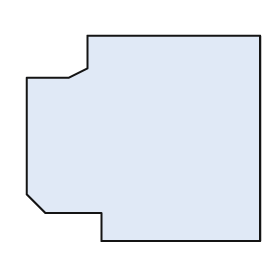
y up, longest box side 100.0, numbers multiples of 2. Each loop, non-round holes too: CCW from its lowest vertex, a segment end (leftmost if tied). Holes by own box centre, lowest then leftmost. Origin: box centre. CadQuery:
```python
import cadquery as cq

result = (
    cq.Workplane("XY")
    .moveTo(-18.0, -44.0)
    .lineTo(50.0, -44.0)
    .lineTo(50.0, 44.0)
    .lineTo(-24.0, 44.0)
    .lineTo(-24.0, 30.0)
    .lineTo(-32.0, 26.0)
    .lineTo(-50.0, 26.0)
    .lineTo(-50.0, -24.0)
    .lineTo(-42.0, -32.0)
    .lineTo(-18.0, -32.0)
    .close()
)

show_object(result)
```